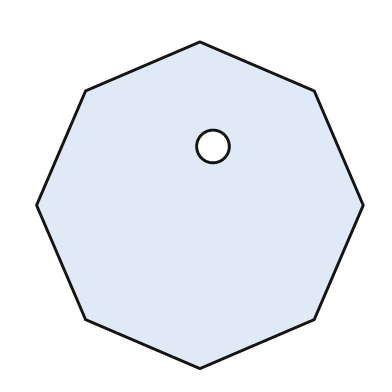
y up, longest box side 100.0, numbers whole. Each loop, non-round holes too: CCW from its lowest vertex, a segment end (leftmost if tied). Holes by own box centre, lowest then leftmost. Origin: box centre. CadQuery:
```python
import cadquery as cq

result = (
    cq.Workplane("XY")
    .moveTo(0.0, -50.0)
    .lineTo(35.0, -35.0)
    .lineTo(50.0, 0.0)
    .lineTo(35.0, 35.0)
    .lineTo(0.0, 50.0)
    .lineTo(-35.0, 35.0)
    .lineTo(-50.0, 0.0)
    .lineTo(-35.0, -35.0)
    .close()
    .moveTo(4.0, 18.0)
    .circle(5.0)
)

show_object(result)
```